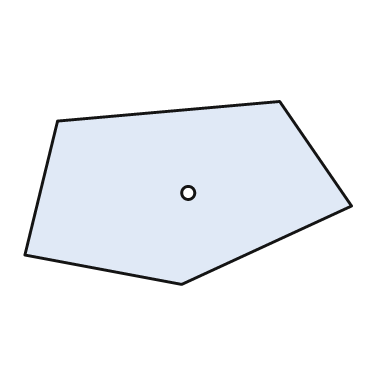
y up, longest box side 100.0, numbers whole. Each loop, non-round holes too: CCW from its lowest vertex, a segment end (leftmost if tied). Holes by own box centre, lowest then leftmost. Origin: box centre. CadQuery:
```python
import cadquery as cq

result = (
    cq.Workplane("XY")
    .moveTo(-2.0, -28.0)
    .lineTo(50.0, -4.0)
    .lineTo(28.0, 28.0)
    .lineTo(-40.0, 22.0)
    .lineTo(-50.0, -19.0)
    .close()
    .moveTo(0.0, 0.0)
    .circle(2.0)
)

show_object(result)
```